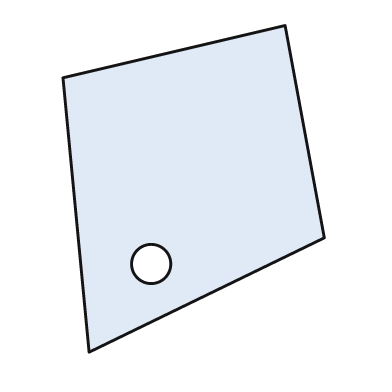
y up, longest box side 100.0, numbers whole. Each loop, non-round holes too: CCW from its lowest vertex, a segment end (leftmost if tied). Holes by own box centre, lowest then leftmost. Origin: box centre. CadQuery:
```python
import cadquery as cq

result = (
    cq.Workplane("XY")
    .moveTo(-32.0, -50.0)
    .lineTo(40.0, -15.0)
    .lineTo(28.0, 50.0)
    .lineTo(-40.0, 34.0)
    .close()
    .moveTo(-13.0, -23.0)
    .circle(6.0)
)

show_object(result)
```